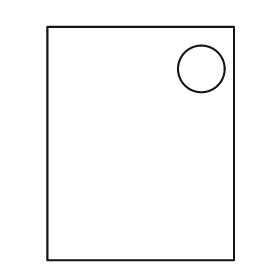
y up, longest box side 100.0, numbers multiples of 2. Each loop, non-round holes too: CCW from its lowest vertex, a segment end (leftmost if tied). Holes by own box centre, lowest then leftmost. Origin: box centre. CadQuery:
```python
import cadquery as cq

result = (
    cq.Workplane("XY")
    .moveTo(-40.0, -50.0)
    .lineTo(40.0, -50.0)
    .lineTo(40.0, 50.0)
    .lineTo(-40.0, 50.0)
    .close()
    .moveTo(26.0, 32.0)
    .circle(10.0)
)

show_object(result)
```